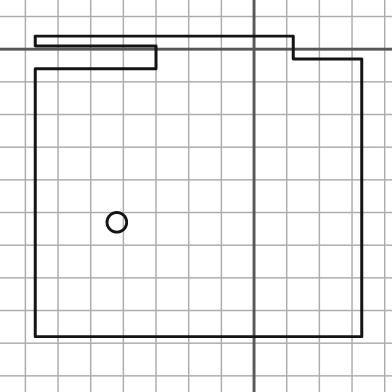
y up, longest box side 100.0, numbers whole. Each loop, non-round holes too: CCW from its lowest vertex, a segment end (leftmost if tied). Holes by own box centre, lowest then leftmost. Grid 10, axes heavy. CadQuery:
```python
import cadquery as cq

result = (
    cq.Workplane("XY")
    .moveTo(-67.0, -88.0)
    .lineTo(33.0, -88.0)
    .lineTo(33.0, -3.0)
    .lineTo(12.0, -3.0)
    .lineTo(12.0, 4.0)
    .lineTo(-67.0, 4.0)
    .lineTo(-67.0, 1.0)
    .lineTo(-30.0, 1.0)
    .lineTo(-30.0, -6.0)
    .lineTo(-67.0, -6.0)
    .close()
    .moveTo(-42.0, -53.0)
    .circle(3.0)
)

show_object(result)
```